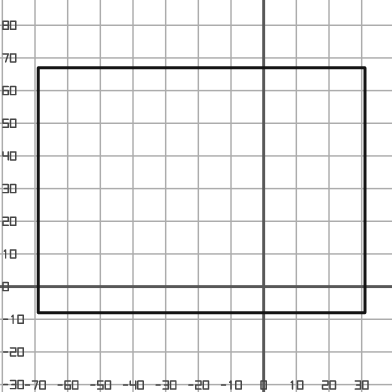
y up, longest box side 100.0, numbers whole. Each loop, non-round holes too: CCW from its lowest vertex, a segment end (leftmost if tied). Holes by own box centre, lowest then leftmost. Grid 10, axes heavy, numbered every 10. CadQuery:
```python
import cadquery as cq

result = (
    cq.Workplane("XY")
    .moveTo(-69.0, -8.0)
    .lineTo(31.0, -8.0)
    .lineTo(31.0, 67.0)
    .lineTo(-69.0, 67.0)
    .close()
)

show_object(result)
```